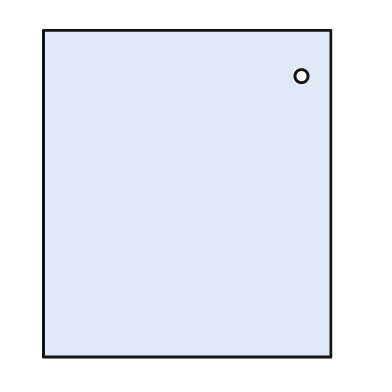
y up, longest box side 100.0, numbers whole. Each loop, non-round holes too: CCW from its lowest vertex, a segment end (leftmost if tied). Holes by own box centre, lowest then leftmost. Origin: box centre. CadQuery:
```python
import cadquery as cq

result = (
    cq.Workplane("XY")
    .moveTo(-44.0, -50.0)
    .lineTo(44.0, -50.0)
    .lineTo(44.0, 50.0)
    .lineTo(-44.0, 50.0)
    .close()
    .moveTo(35.0, 36.0)
    .circle(2.0)
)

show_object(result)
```